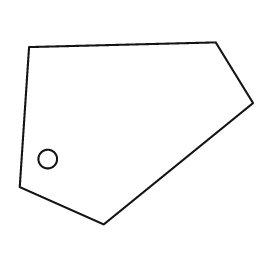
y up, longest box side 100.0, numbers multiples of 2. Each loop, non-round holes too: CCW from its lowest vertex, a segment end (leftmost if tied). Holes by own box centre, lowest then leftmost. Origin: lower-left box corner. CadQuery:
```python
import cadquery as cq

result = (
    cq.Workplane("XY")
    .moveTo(36.0, 0.0)
    .lineTo(100.0, 52.0)
    .lineTo(84.0, 78.0)
    .lineTo(4.0, 76.0)
    .lineTo(0.0, 16.0)
    .close()
    .moveTo(12.0, 28.0)
    .circle(4.0)
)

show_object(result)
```